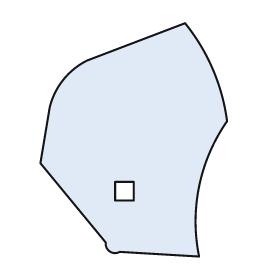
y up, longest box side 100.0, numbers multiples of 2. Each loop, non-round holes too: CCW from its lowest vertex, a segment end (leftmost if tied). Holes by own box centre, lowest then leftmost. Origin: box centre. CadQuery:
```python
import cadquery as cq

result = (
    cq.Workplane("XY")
    .moveTo(28.0, -50.0)
    .threePointArc((28.0, -20.0), (40.0, 8.0))
    .threePointArc((34.0, 30.0), (22.0, 50.0))
    .lineTo(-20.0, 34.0)
    .threePointArc((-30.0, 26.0), (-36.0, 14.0))
    .lineTo(-40.0, -10.0)
    .lineTo(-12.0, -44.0)
    .threePointArc((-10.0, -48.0), (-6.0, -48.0))
    .close()
    .moveTo(-8.0, -26.0)
    .lineTo(0.0, -26.0)
    .lineTo(0.0, -18.0)
    .lineTo(-8.0, -18.0)
    .close()
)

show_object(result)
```